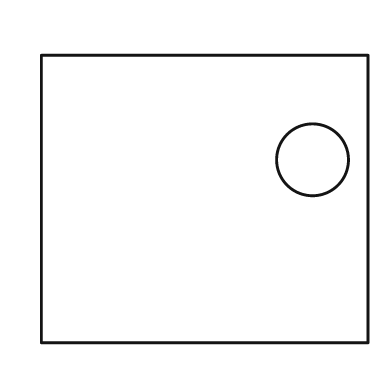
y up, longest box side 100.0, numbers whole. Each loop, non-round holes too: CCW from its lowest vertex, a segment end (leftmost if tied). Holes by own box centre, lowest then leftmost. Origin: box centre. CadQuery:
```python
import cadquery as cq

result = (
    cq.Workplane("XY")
    .moveTo(-50.0, -44.0)
    .lineTo(50.0, -44.0)
    .lineTo(50.0, 44.0)
    .lineTo(-50.0, 44.0)
    .close()
    .moveTo(33.0, 12.0)
    .circle(11.0)
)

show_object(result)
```